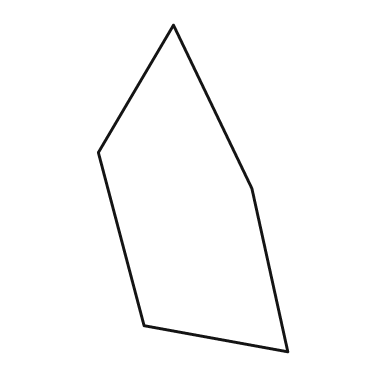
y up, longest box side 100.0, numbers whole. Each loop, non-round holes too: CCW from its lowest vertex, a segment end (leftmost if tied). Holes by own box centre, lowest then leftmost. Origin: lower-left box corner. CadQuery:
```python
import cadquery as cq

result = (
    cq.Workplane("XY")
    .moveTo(58.0, 0.0)
    .lineTo(47.0, 50.0)
    .lineTo(23.0, 100.0)
    .lineTo(0.0, 61.0)
    .lineTo(14.0, 8.0)
    .close()
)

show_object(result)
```